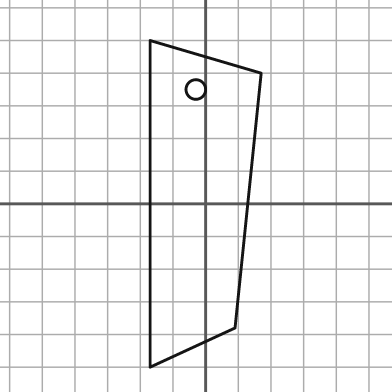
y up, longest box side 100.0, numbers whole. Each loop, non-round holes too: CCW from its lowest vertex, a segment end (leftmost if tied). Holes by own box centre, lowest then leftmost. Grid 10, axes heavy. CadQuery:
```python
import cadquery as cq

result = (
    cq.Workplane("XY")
    .moveTo(-17.0, -50.0)
    .lineTo(9.0, -38.0)
    .lineTo(17.0, 40.0)
    .lineTo(-17.0, 50.0)
    .close()
    .moveTo(-3.0, 35.0)
    .circle(3.0)
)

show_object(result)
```